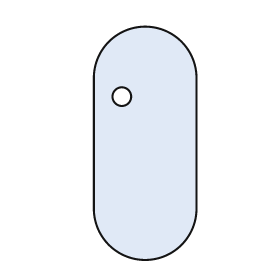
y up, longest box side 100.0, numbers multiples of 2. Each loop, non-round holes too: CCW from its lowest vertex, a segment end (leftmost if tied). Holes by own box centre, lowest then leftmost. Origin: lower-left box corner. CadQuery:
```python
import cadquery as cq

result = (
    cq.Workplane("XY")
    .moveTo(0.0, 22.0)
    .threePointArc((22.0, 0.0), (44.0, 22.0))
    .lineTo(44.0, 78.0)
    .threePointArc((22.0, 100.0), (0.0, 78.0))
    .close()
    .moveTo(12.0, 70.0)
    .circle(4.0)
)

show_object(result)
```